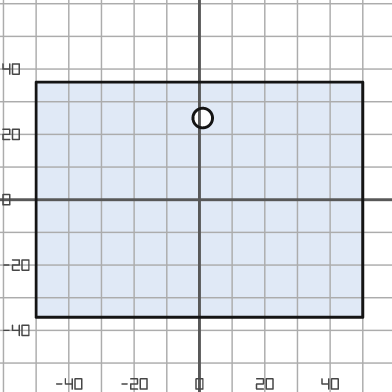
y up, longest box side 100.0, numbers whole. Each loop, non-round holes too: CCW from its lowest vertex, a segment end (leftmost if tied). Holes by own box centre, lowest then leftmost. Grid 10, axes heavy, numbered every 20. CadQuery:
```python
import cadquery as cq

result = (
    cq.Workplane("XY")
    .moveTo(-50.0, -36.0)
    .lineTo(50.0, -36.0)
    .lineTo(50.0, 36.0)
    .lineTo(-50.0, 36.0)
    .close()
    .moveTo(1.0, 25.0)
    .circle(3.0)
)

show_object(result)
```